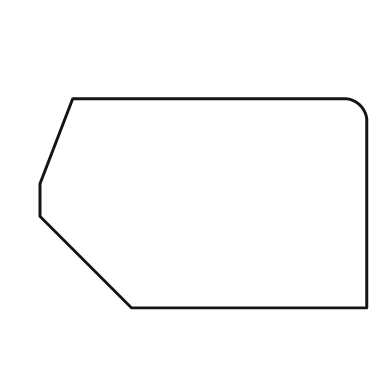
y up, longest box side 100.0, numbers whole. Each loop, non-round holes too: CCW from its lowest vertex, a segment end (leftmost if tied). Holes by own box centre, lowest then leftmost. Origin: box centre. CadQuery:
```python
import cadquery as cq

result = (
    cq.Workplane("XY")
    .moveTo(-22.0, -32.0)
    .lineTo(50.0, -32.0)
    .lineTo(50.0, 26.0)
    .threePointArc((48.0, 30.0), (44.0, 32.0))
    .lineTo(-40.0, 32.0)
    .lineTo(-50.0, 6.0)
    .lineTo(-50.0, -4.0)
    .close()
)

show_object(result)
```